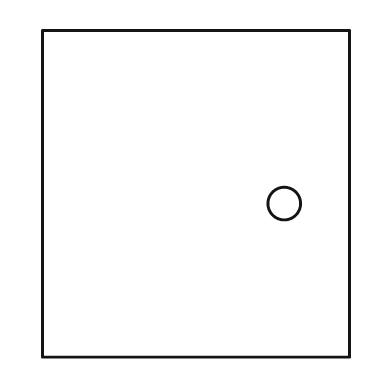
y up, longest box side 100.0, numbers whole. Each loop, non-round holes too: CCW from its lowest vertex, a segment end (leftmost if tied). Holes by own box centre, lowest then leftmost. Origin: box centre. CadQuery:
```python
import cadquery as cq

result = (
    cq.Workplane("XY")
    .moveTo(-47.0, -50.0)
    .lineTo(47.0, -50.0)
    .lineTo(47.0, 50.0)
    .lineTo(-47.0, 50.0)
    .close()
    .moveTo(27.0, -3.0)
    .circle(5.0)
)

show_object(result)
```